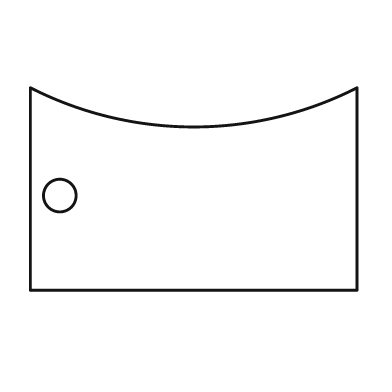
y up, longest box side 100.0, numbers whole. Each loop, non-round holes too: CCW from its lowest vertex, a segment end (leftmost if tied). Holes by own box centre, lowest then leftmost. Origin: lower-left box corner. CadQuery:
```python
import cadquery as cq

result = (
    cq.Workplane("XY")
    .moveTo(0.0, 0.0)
    .lineTo(100.0, 0.0)
    .lineTo(100.0, 62.0)
    .threePointArc((50.0, 50.0), (0.0, 62.0))
    .close()
    .moveTo(9.0, 29.0)
    .circle(5.0)
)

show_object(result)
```